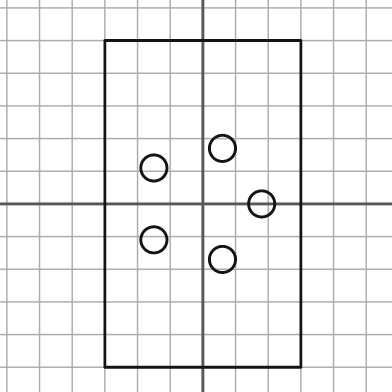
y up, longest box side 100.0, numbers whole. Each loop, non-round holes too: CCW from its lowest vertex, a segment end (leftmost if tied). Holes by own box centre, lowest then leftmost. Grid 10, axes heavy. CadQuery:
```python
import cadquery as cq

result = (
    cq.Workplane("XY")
    .moveTo(-30.0, -50.0)
    .lineTo(30.0, -50.0)
    .lineTo(30.0, 50.0)
    .lineTo(-30.0, 50.0)
    .close()
    .moveTo(6.0, -17.0)
    .circle(4.0)
    .moveTo(-15.0, -11.0)
    .circle(4.0)
    .moveTo(18.0, 0.0)
    .circle(4.0)
    .moveTo(-15.0, 11.0)
    .circle(4.0)
    .moveTo(6.0, 17.0)
    .circle(4.0)
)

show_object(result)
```